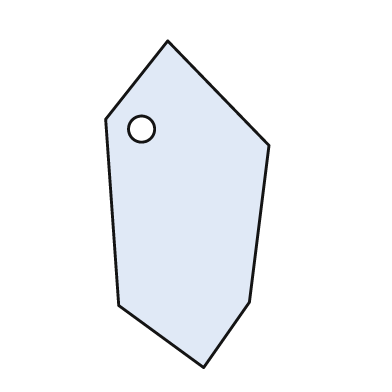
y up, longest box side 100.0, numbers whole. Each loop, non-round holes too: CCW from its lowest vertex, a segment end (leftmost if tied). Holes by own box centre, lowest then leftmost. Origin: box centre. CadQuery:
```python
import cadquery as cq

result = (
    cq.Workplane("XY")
    .moveTo(5.0, -50.0)
    .lineTo(19.0, -30.0)
    .lineTo(25.0, 18.0)
    .lineTo(-6.0, 50.0)
    .lineTo(-25.0, 26.0)
    .lineTo(-21.0, -31.0)
    .close()
    .moveTo(-14.0, 23.0)
    .circle(4.0)
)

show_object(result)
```